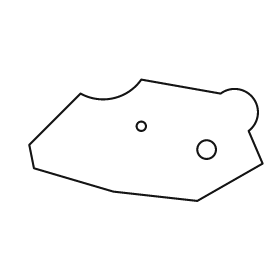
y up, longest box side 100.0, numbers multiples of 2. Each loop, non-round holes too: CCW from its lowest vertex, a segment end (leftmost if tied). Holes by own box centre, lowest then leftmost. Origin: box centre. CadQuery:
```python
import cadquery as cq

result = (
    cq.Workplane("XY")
    .moveTo(22.0, -26.0)
    .lineTo(50.0, -10.0)
    .lineTo(44.0, 4.0)
    .threePointArc((46.0, 18.0), (32.0, 20.0))
    .lineTo(-2.0, 26.0)
    .threePointArc((-14.0, 18.0), (-28.0, 20.0))
    .lineTo(-50.0, -2.0)
    .lineTo(-48.0, -12.0)
    .lineTo(-14.0, -22.0)
    .close()
    .moveTo(26.0, -4.0)
    .circle(4.0)
    .moveTo(-2.0, 6.0)
    .circle(2.0)
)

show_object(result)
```